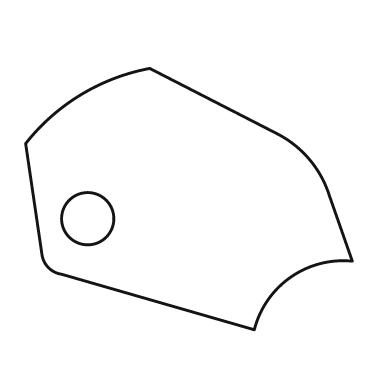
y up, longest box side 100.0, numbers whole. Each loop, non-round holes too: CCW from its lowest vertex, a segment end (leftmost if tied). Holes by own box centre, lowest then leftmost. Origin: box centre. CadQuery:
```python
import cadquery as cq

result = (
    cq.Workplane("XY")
    .moveTo(20.0, -40.0)
    .threePointArc((31.0, -24.0), (50.0, -19.0))
    .lineTo(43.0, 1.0)
    .threePointArc((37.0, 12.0), (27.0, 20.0))
    .lineTo(-12.0, 40.0)
    .threePointArc((-33.0, 32.0), (-50.0, 17.0))
    .lineTo(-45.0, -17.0)
    .threePointArc((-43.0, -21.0), (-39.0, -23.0))
    .close()
    .moveTo(-31.0, -6.0)
    .circle(8.0)
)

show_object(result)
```